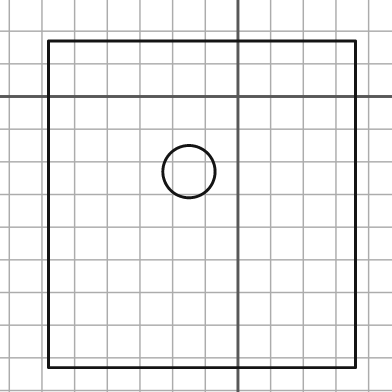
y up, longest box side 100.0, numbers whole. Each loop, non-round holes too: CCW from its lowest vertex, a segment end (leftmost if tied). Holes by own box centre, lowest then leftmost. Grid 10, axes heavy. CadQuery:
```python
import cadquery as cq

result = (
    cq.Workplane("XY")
    .moveTo(-58.0, -83.0)
    .lineTo(36.0, -83.0)
    .lineTo(36.0, 17.0)
    .lineTo(-58.0, 17.0)
    .close()
    .moveTo(-15.0, -23.0)
    .circle(8.0)
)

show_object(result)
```